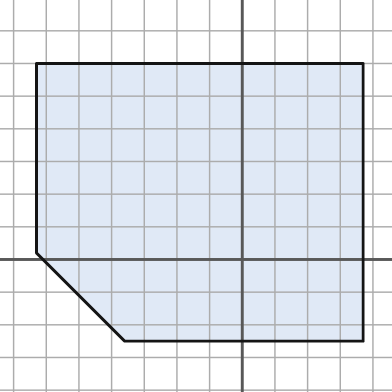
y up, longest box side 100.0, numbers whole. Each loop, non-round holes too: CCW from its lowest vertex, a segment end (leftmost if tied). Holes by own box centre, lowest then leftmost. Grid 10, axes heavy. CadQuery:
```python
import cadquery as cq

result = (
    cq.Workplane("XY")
    .moveTo(-36.0, -25.0)
    .lineTo(37.0, -25.0)
    .lineTo(37.0, 60.0)
    .lineTo(-63.0, 60.0)
    .lineTo(-63.0, 2.0)
    .close()
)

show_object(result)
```